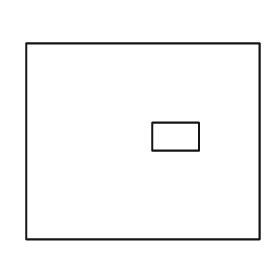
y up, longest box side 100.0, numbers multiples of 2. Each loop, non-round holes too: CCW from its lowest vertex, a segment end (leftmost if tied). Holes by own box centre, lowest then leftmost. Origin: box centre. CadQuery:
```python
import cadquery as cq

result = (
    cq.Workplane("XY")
    .moveTo(-50.0, -42.0)
    .lineTo(50.0, -42.0)
    .lineTo(50.0, 42.0)
    .lineTo(-50.0, 42.0)
    .close()
    .moveTo(4.0, -4.0)
    .lineTo(24.0, -4.0)
    .lineTo(24.0, 8.0)
    .lineTo(4.0, 8.0)
    .close()
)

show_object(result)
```